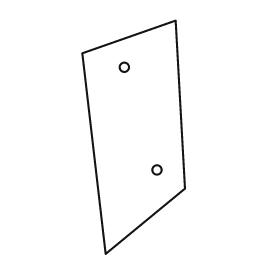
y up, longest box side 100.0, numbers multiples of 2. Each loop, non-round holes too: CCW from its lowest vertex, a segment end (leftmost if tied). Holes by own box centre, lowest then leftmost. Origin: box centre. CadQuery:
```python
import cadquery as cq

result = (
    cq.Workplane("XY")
    .moveTo(-12.0, -50.0)
    .lineTo(22.0, -22.0)
    .lineTo(18.0, 50.0)
    .lineTo(-22.0, 36.0)
    .close()
    .moveTo(10.0, -14.0)
    .circle(2.0)
    .moveTo(-4.0, 30.0)
    .circle(2.0)
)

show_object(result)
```